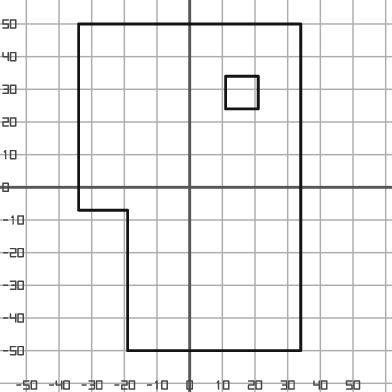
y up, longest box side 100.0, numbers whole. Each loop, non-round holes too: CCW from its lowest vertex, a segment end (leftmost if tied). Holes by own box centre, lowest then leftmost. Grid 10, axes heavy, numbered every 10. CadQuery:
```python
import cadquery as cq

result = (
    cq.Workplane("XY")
    .moveTo(-19.0, -50.0)
    .lineTo(34.0, -50.0)
    .lineTo(34.0, 50.0)
    .lineTo(-34.0, 50.0)
    .lineTo(-34.0, -7.0)
    .lineTo(-19.0, -7.0)
    .close()
    .moveTo(11.0, 24.0)
    .lineTo(21.0, 24.0)
    .lineTo(21.0, 34.0)
    .lineTo(11.0, 34.0)
    .close()
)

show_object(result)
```